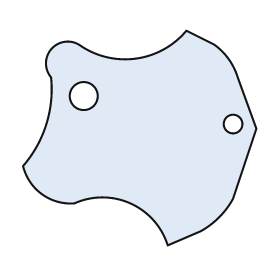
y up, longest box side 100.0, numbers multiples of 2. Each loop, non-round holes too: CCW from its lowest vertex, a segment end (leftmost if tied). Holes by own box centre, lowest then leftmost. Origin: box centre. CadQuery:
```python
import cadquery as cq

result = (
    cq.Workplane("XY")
    .moveTo(12.0, -46.0)
    .lineTo(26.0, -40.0)
    .threePointArc((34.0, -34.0), (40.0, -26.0))
    .lineTo(50.0, 4.0)
    .lineTo(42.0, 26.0)
    .threePointArc((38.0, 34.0), (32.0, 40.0))
    .lineTo(20.0, 46.0)
    .threePointArc((-2.0, 34.0), (-26.0, 40.0))
    .threePointArc((-38.0, 38.0), (-38.0, 26.0))
    .threePointArc((-40.0, 6.0), (-50.0, -12.0))
    .threePointArc((-42.0, -24.0), (-28.0, -28.0))
    .threePointArc((-4.0, -28.0), (12.0, -46.0))
    .close()
    .moveTo(40.0, 6.0)
    .circle(4.0)
    .moveTo(-24.0, 18.0)
    .circle(6.0)
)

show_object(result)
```